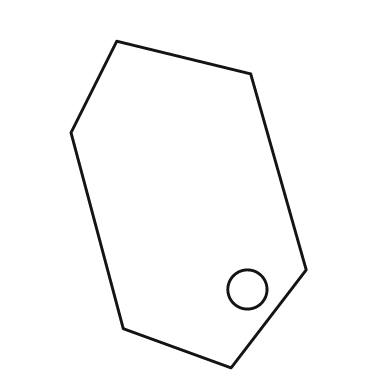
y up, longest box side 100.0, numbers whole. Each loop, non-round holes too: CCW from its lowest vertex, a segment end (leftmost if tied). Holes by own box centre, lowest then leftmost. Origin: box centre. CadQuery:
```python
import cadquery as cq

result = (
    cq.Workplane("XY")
    .moveTo(13.0, -50.0)
    .lineTo(36.0, -20.0)
    .lineTo(19.0, 40.0)
    .lineTo(-22.0, 50.0)
    .lineTo(-36.0, 22.0)
    .lineTo(-20.0, -38.0)
    .close()
    .moveTo(18.0, -26.0)
    .circle(6.0)
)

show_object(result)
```